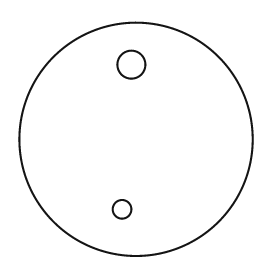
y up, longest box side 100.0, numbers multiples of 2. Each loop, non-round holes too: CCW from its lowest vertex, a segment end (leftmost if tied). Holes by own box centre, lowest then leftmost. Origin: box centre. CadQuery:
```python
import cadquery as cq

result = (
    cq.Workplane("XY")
    .moveTo(0.0, 0.0)
    .circle(50.0)
    .moveTo(-6.0, -30.0)
    .circle(4.0)
    .moveTo(-2.0, 32.0)
    .circle(6.0)
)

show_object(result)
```